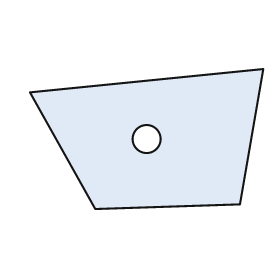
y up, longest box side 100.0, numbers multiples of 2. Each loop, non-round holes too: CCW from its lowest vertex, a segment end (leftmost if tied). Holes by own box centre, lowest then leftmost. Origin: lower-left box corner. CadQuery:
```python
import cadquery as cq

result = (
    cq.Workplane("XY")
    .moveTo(28.0, 0.0)
    .lineTo(90.0, 2.0)
    .lineTo(100.0, 60.0)
    .lineTo(0.0, 50.0)
    .close()
    .moveTo(50.0, 30.0)
    .circle(6.0)
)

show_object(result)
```